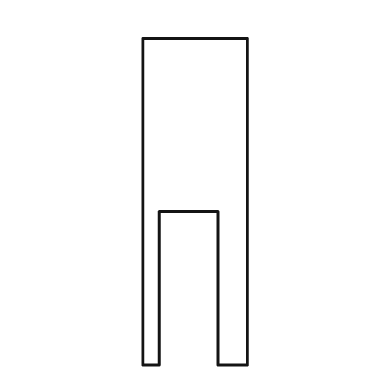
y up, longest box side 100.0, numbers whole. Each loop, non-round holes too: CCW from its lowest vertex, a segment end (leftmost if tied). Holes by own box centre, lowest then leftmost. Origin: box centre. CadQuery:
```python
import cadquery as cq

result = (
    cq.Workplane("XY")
    .moveTo(-16.0, -50.0)
    .lineTo(-11.0, -50.0)
    .lineTo(-11.0, -3.0)
    .lineTo(7.0, -3.0)
    .lineTo(7.0, -50.0)
    .lineTo(16.0, -50.0)
    .lineTo(16.0, 50.0)
    .lineTo(-16.0, 50.0)
    .close()
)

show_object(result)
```